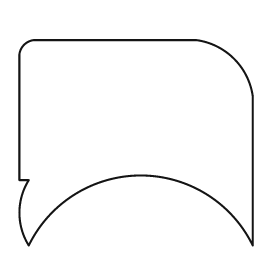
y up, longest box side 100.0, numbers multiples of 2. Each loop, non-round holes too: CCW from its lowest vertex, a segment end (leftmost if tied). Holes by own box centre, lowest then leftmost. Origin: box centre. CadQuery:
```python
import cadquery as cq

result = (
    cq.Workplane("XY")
    .moveTo(-46.0, -44.0)
    .threePointArc((2.0, -14.0), (50.0, -44.0))
    .lineTo(50.0, 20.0)
    .threePointArc((42.0, 36.0), (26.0, 44.0))
    .lineTo(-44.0, 44.0)
    .threePointArc((-48.0, 42.0), (-50.0, 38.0))
    .lineTo(-50.0, -16.0)
    .lineTo(-46.0, -16.0)
    .threePointArc((-50.0, -30.0), (-46.0, -44.0))
    .close()
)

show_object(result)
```